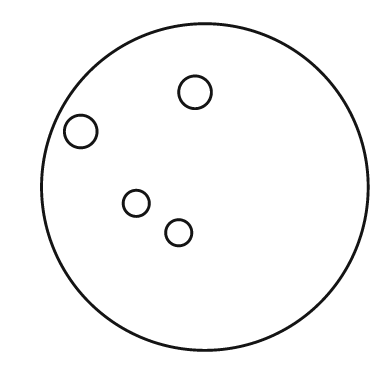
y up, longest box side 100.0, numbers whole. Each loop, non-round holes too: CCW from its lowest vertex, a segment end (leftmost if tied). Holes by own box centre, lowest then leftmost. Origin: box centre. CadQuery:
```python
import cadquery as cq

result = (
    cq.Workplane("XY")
    .moveTo(0.0, 0.0)
    .circle(50.0)
    .moveTo(-8.0, -14.0)
    .circle(4.0)
    .moveTo(-21.0, -5.0)
    .circle(4.0)
    .moveTo(-38.0, 17.0)
    .circle(5.0)
    .moveTo(-3.0, 29.0)
    .circle(5.0)
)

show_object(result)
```